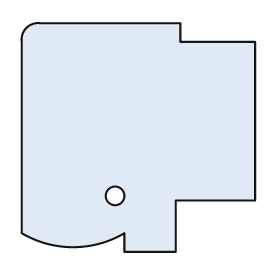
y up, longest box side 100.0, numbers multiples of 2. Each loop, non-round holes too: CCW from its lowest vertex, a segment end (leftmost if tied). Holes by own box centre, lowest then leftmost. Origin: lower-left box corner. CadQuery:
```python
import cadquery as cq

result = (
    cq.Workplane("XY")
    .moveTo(44.0, 0.0)
    .lineTo(66.0, 0.0)
    .lineTo(66.0, 22.0)
    .lineTo(100.0, 22.0)
    .lineTo(100.0, 90.0)
    .lineTo(68.0, 90.0)
    .lineTo(68.0, 98.0)
    .lineTo(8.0, 98.0)
    .threePointArc((2.0, 96.0), (0.0, 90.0))
    .lineTo(0.0, 8.0)
    .threePointArc((22.0, 2.0), (44.0, 8.0))
    .close()
    .moveTo(40.0, 24.0)
    .circle(4.0)
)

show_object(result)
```